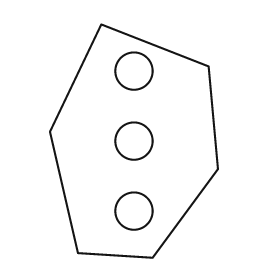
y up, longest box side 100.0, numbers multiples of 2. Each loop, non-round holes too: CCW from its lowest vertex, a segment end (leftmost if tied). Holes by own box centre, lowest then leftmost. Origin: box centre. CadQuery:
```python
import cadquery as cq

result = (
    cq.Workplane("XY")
    .moveTo(8.0, -50.0)
    .lineTo(36.0, -12.0)
    .lineTo(32.0, 32.0)
    .lineTo(-14.0, 50.0)
    .lineTo(-36.0, 4.0)
    .lineTo(-24.0, -48.0)
    .close()
    .moveTo(0.0, -30.0)
    .circle(8.0)
    .moveTo(0.0, 0.0)
    .circle(8.0)
    .moveTo(0.0, 30.0)
    .circle(8.0)
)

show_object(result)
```